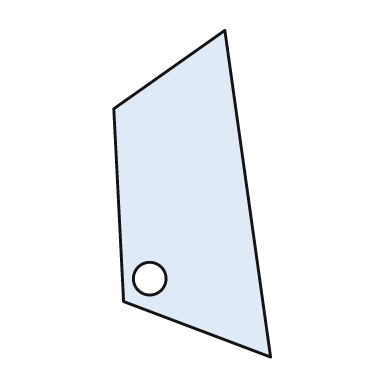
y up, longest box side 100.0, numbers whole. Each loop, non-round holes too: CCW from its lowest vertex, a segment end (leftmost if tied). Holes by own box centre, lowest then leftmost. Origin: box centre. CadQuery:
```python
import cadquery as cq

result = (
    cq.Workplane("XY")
    .moveTo(24.0, -50.0)
    .lineTo(10.0, 50.0)
    .lineTo(-24.0, 26.0)
    .lineTo(-21.0, -33.0)
    .close()
    .moveTo(-13.0, -26.0)
    .circle(5.0)
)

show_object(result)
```